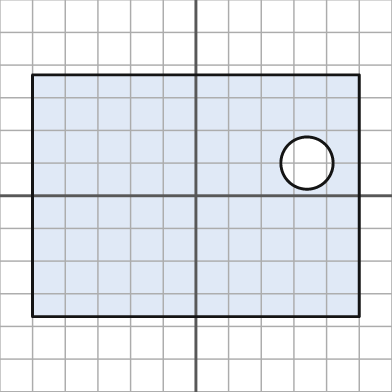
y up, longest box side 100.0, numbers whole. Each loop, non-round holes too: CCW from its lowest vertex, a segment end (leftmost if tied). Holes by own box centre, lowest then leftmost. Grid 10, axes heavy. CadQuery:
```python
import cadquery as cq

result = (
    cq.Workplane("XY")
    .moveTo(-50.0, -37.0)
    .lineTo(50.0, -37.0)
    .lineTo(50.0, 37.0)
    .lineTo(-50.0, 37.0)
    .close()
    .moveTo(34.0, 10.0)
    .circle(8.0)
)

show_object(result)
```